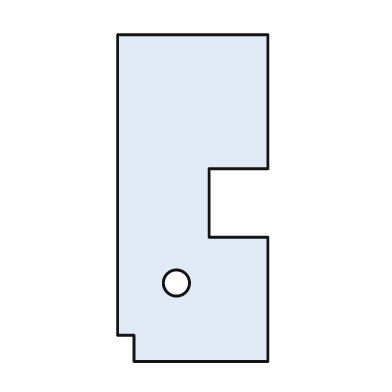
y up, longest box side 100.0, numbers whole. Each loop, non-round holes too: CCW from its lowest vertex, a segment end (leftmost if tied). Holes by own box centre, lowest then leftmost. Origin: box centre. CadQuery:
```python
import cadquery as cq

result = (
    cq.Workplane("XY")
    .moveTo(-18.0, -50.0)
    .lineTo(23.0, -50.0)
    .lineTo(23.0, -12.0)
    .lineTo(5.0, -12.0)
    .lineTo(5.0, 9.0)
    .lineTo(23.0, 9.0)
    .lineTo(23.0, 50.0)
    .lineTo(-23.0, 50.0)
    .lineTo(-23.0, -42.0)
    .lineTo(-18.0, -42.0)
    .close()
    .moveTo(-5.0, -26.0)
    .circle(4.0)
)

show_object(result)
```